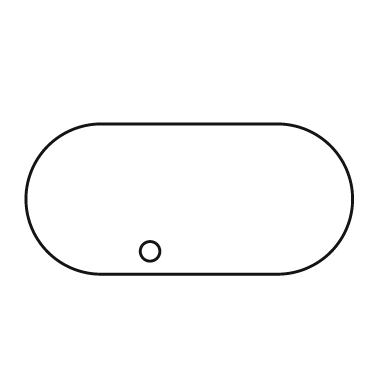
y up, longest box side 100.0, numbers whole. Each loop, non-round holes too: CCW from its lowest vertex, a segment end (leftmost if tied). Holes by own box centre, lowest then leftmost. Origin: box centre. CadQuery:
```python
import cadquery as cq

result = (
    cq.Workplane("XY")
    .moveTo(-27.0, -23.0)
    .lineTo(27.0, -23.0)
    .threePointArc((50.0, 0.0), (27.0, 23.0))
    .lineTo(-27.0, 23.0)
    .threePointArc((-50.0, 0.0), (-27.0, -23.0))
    .close()
    .moveTo(-12.0, -16.0)
    .circle(3.0)
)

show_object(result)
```